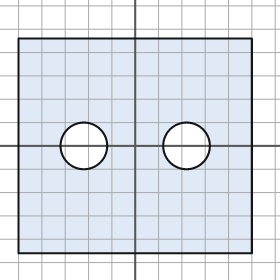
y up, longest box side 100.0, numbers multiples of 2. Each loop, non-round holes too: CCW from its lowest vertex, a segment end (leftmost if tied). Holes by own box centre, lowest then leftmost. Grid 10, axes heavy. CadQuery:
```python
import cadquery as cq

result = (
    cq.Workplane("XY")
    .moveTo(-50.0, -46.0)
    .lineTo(50.0, -46.0)
    .lineTo(50.0, 46.0)
    .lineTo(-50.0, 46.0)
    .close()
    .moveTo(-22.0, 0.0)
    .circle(10.0)
    .moveTo(22.0, 0.0)
    .circle(10.0)
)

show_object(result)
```